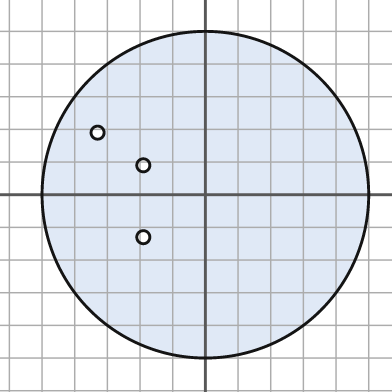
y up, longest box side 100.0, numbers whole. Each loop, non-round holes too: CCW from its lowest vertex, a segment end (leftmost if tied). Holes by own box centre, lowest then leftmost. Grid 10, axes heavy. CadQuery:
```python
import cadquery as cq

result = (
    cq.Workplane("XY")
    .moveTo(0.0, 0.0)
    .circle(50.0)
    .moveTo(-19.0, -13.0)
    .circle(2.0)
    .moveTo(-19.0, 9.0)
    .circle(2.0)
    .moveTo(-33.0, 19.0)
    .circle(2.0)
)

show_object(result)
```